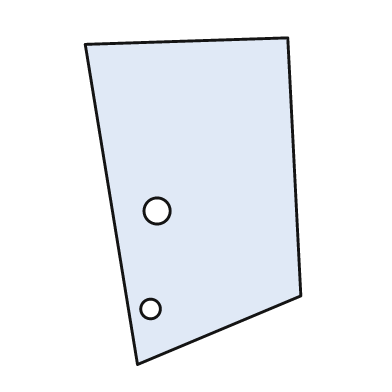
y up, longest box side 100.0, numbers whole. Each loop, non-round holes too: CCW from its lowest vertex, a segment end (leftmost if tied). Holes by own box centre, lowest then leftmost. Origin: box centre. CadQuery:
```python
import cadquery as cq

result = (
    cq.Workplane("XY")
    .moveTo(-17.0, -50.0)
    .lineTo(33.0, -29.0)
    .lineTo(29.0, 50.0)
    .lineTo(-33.0, 48.0)
    .close()
    .moveTo(-13.0, -33.0)
    .circle(3.0)
    .moveTo(-11.0, -3.0)
    .circle(4.0)
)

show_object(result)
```